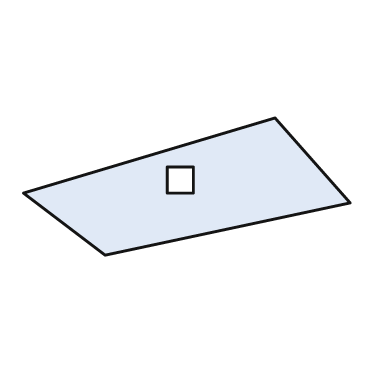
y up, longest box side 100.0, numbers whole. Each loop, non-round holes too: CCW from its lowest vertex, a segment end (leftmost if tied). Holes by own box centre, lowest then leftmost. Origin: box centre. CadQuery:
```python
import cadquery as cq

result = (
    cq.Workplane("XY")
    .moveTo(-25.0, -21.0)
    .lineTo(50.0, -5.0)
    .lineTo(27.0, 21.0)
    .lineTo(-50.0, -2.0)
    .close()
    .moveTo(-6.0, -2.0)
    .lineTo(2.0, -2.0)
    .lineTo(2.0, 6.0)
    .lineTo(-6.0, 6.0)
    .close()
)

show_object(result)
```